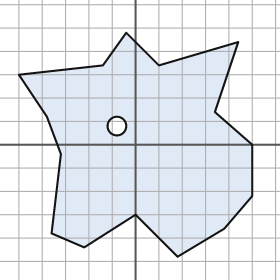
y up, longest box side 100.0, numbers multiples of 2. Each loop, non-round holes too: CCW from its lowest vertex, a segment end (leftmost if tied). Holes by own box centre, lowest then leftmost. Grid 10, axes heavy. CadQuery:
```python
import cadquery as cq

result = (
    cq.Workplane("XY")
    .moveTo(18.0, -48.0)
    .lineTo(38.0, -36.0)
    .lineTo(50.0, -22.0)
    .lineTo(50.0, 0.0)
    .lineTo(34.0, 14.0)
    .lineTo(44.0, 44.0)
    .lineTo(10.0, 34.0)
    .lineTo(-4.0, 48.0)
    .lineTo(-14.0, 34.0)
    .lineTo(-50.0, 30.0)
    .lineTo(-38.0, 12.0)
    .lineTo(-32.0, -4.0)
    .lineTo(-36.0, -38.0)
    .lineTo(-22.0, -44.0)
    .lineTo(0.0, -30.0)
    .close()
    .moveTo(-8.0, 8.0)
    .circle(4.0)
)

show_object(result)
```